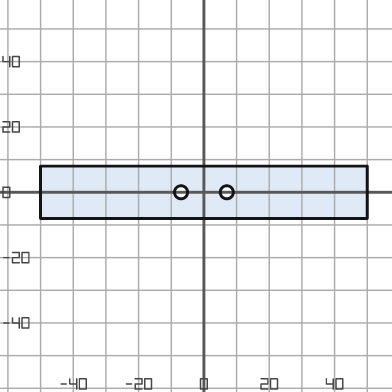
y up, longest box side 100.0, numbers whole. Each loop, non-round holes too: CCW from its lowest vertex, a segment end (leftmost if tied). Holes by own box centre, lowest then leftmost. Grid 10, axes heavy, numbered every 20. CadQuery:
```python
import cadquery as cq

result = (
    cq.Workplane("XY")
    .moveTo(-50.0, -8.0)
    .lineTo(50.0, -8.0)
    .lineTo(50.0, 8.0)
    .lineTo(-50.0, 8.0)
    .close()
    .moveTo(-7.0, 0.0)
    .circle(2.0)
    .moveTo(7.0, 0.0)
    .circle(2.0)
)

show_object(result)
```